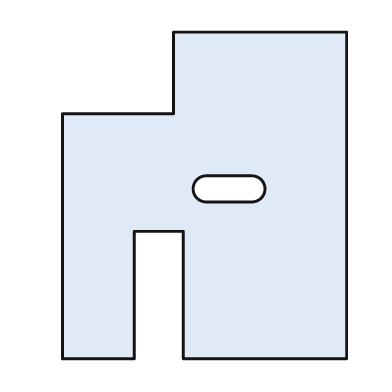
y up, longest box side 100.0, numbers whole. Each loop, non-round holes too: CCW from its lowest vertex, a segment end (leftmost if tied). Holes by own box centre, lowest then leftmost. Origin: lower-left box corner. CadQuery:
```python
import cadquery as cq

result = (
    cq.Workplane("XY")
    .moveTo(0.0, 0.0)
    .lineTo(22.0, 0.0)
    .lineTo(22.0, 39.0)
    .lineTo(37.0, 39.0)
    .lineTo(37.0, 0.0)
    .lineTo(87.0, 0.0)
    .lineTo(87.0, 100.0)
    .lineTo(34.0, 100.0)
    .lineTo(34.0, 75.0)
    .lineTo(0.0, 75.0)
    .close()
    .moveTo(44.0, 48.0)
    .lineTo(58.0, 48.0)
    .threePointArc((62.0, 52.0), (58.0, 56.0))
    .lineTo(44.0, 56.0)
    .threePointArc((40.0, 52.0), (44.0, 48.0))
    .close()
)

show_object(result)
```